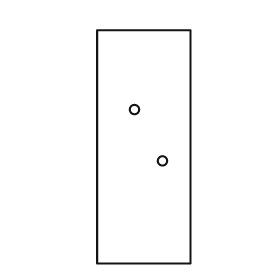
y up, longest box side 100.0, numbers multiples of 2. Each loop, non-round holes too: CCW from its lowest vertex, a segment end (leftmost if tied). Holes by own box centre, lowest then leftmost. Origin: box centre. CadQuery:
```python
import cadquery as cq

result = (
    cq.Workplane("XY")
    .moveTo(-20.0, -50.0)
    .lineTo(20.0, -50.0)
    .lineTo(20.0, 50.0)
    .lineTo(-20.0, 50.0)
    .close()
    .moveTo(8.0, -6.0)
    .circle(2.0)
    .moveTo(-4.0, 16.0)
    .circle(2.0)
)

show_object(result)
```